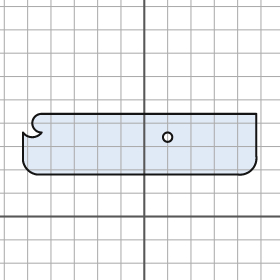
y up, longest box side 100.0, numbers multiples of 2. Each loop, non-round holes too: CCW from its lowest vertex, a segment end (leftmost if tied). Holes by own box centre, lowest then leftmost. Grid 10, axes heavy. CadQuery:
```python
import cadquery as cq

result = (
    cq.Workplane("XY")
    .moveTo(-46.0, 18.0)
    .lineTo(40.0, 18.0)
    .threePointArc((46.0, 20.0), (48.0, 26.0))
    .lineTo(48.0, 44.0)
    .lineTo(-44.0, 44.0)
    .threePointArc((-48.0, 40.0), (-44.0, 36.0))
    .threePointArc((-48.0, 34.0), (-52.0, 36.0))
    .lineTo(-52.0, 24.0)
    .threePointArc((-50.0, 20.0), (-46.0, 18.0))
    .close()
    .moveTo(10.0, 34.0)
    .circle(2.0)
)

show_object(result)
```